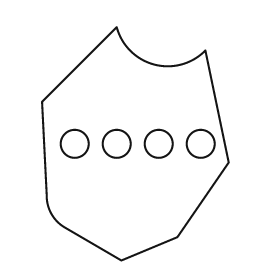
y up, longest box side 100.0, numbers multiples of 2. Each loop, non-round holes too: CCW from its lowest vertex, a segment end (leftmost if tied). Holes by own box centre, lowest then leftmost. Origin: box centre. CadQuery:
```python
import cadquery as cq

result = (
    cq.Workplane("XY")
    .moveTo(-6.0, -50.0)
    .lineTo(18.0, -40.0)
    .lineTo(40.0, -8.0)
    .lineTo(30.0, 40.0)
    .threePointArc((8.0, 34.0), (-8.0, 50.0))
    .lineTo(-40.0, 18.0)
    .lineTo(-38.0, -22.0)
    .threePointArc((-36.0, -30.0), (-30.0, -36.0))
    .close()
    .moveTo(-26.0, 0.0)
    .circle(6.0)
    .moveTo(-8.0, 0.0)
    .circle(6.0)
    .moveTo(10.0, 0.0)
    .circle(6.0)
    .moveTo(28.0, 0.0)
    .circle(6.0)
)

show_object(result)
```